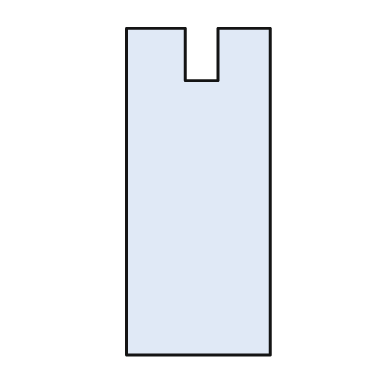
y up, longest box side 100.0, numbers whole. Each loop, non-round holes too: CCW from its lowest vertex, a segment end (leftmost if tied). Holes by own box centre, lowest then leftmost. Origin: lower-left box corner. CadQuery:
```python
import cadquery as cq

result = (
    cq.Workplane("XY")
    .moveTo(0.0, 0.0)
    .lineTo(44.0, 0.0)
    .lineTo(44.0, 100.0)
    .lineTo(28.0, 100.0)
    .lineTo(28.0, 84.0)
    .lineTo(18.0, 84.0)
    .lineTo(18.0, 100.0)
    .lineTo(0.0, 100.0)
    .close()
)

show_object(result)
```